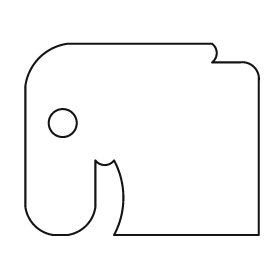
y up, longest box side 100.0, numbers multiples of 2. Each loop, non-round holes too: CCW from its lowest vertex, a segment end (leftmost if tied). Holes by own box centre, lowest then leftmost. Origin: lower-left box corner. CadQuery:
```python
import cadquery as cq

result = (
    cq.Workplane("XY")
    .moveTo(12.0, 0.0)
    .lineTo(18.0, 0.0)
    .threePointArc((26.0, 4.0), (30.0, 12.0))
    .lineTo(30.0, 32.0)
    .threePointArc((34.0, 30.0), (38.0, 32.0))
    .threePointArc((42.0, 16.0), (38.0, 0.0))
    .lineTo(100.0, 0.0)
    .lineTo(100.0, 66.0)
    .threePointArc((98.0, 72.0), (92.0, 74.0))
    .lineTo(80.0, 74.0)
    .threePointArc((82.0, 78.0), (80.0, 82.0))
    .lineTo(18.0, 82.0)
    .threePointArc((6.0, 76.0), (0.0, 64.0))
    .lineTo(0.0, 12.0)
    .threePointArc((4.0, 4.0), (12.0, 0.0))
    .close()
    .moveTo(16.0, 48.0)
    .circle(6.0)
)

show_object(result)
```